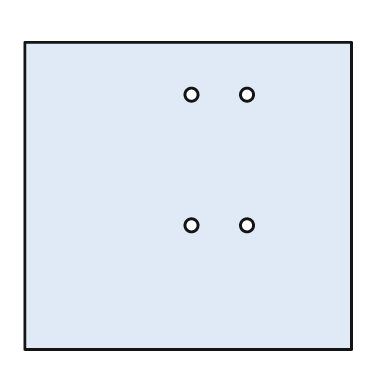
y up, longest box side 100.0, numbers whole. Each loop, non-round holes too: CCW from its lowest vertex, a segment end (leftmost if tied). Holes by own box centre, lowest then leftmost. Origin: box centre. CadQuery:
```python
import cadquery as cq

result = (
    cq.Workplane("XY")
    .moveTo(-50.0, -47.0)
    .lineTo(50.0, -47.0)
    .lineTo(50.0, 47.0)
    .lineTo(-50.0, 47.0)
    .close()
    .moveTo(1.0, -9.0)
    .circle(2.0)
    .moveTo(18.0, -9.0)
    .circle(2.0)
    .moveTo(1.0, 31.0)
    .circle(2.0)
    .moveTo(18.0, 31.0)
    .circle(2.0)
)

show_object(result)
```